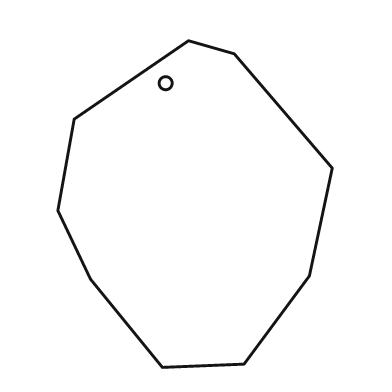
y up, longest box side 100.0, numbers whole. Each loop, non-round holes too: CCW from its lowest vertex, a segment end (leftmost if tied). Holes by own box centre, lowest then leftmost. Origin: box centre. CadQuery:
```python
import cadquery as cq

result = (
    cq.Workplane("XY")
    .moveTo(-10.0, -50.0)
    .lineTo(15.0, -49.0)
    .lineTo(35.0, -22.0)
    .lineTo(42.0, 11.0)
    .lineTo(12.0, 46.0)
    .lineTo(-2.0, 50.0)
    .lineTo(-37.0, 26.0)
    .lineTo(-42.0, -2.0)
    .lineTo(-32.0, -23.0)
    .close()
    .moveTo(-9.0, 37.0)
    .circle(2.0)
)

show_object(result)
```